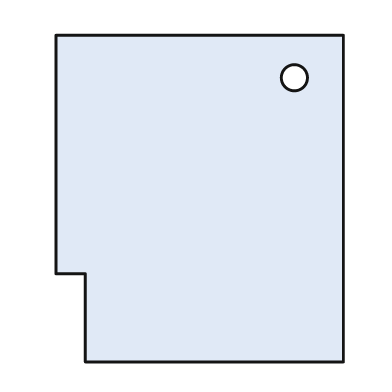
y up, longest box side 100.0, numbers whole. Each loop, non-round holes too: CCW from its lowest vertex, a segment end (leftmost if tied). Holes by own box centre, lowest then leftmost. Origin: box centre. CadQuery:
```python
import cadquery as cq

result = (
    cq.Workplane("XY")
    .moveTo(-35.0, -50.0)
    .lineTo(44.0, -50.0)
    .lineTo(44.0, 50.0)
    .lineTo(-44.0, 50.0)
    .lineTo(-44.0, -23.0)
    .lineTo(-35.0, -23.0)
    .close()
    .moveTo(29.0, 37.0)
    .circle(4.0)
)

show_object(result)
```